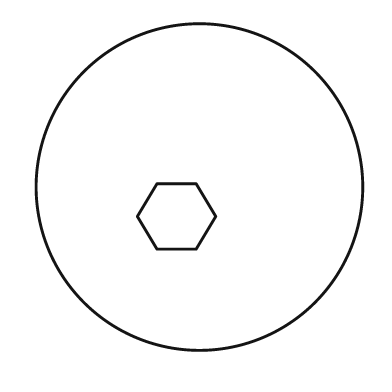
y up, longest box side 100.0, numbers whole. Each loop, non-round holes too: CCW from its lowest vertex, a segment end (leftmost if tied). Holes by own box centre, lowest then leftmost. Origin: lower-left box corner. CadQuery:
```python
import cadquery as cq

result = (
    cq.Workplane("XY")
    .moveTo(50.0, 50.0)
    .circle(50.0)
    .moveTo(37.0, 31.0)
    .lineTo(49.0, 31.0)
    .lineTo(55.0, 41.0)
    .lineTo(49.0, 51.0)
    .lineTo(37.0, 51.0)
    .lineTo(31.0, 41.0)
    .close()
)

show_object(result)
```